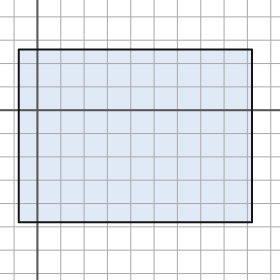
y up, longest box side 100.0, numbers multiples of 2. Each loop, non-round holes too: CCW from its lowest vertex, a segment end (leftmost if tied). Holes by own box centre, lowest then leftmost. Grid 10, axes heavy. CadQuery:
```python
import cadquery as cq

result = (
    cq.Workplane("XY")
    .moveTo(-8.0, -48.0)
    .lineTo(92.0, -48.0)
    .lineTo(92.0, 26.0)
    .lineTo(-8.0, 26.0)
    .close()
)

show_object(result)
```